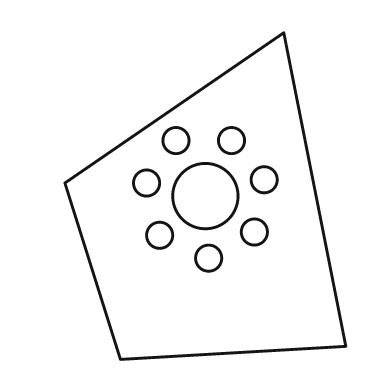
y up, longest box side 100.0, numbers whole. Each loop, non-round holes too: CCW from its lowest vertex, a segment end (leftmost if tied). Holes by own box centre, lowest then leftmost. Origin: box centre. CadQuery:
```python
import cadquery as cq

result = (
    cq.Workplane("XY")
    .moveTo(-26.0, -50.0)
    .lineTo(43.0, -46.0)
    .lineTo(24.0, 50.0)
    .lineTo(-43.0, 4.0)
    .close()
    .moveTo(1.0, -19.0)
    .circle(4.0)
    .moveTo(-14.0, -12.0)
    .circle(4.0)
    .moveTo(15.0, -11.0)
    .circle(4.0)
    .moveTo(0.0, 0.0)
    .circle(10.0)
    .moveTo(-18.0, 4.0)
    .circle(4.0)
    .moveTo(18.0, 5.0)
    .circle(4.0)
    .moveTo(-9.0, 17.0)
    .circle(4.0)
    .moveTo(8.0, 17.0)
    .circle(4.0)
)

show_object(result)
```